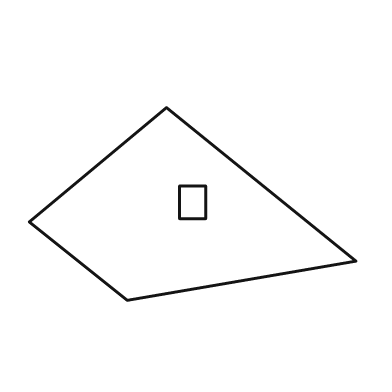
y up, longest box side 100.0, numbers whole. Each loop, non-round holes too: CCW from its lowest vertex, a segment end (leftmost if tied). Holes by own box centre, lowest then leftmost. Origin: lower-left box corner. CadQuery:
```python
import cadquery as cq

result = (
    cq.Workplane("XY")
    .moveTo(30.0, 0.0)
    .lineTo(100.0, 12.0)
    .lineTo(42.0, 59.0)
    .lineTo(0.0, 24.0)
    .close()
    .moveTo(46.0, 25.0)
    .lineTo(54.0, 25.0)
    .lineTo(54.0, 35.0)
    .lineTo(46.0, 35.0)
    .close()
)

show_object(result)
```